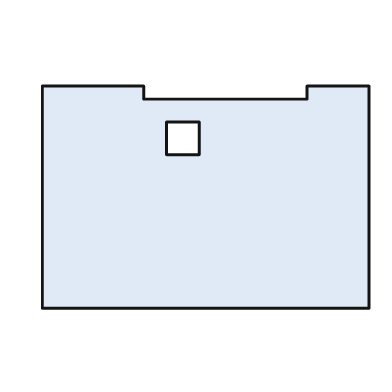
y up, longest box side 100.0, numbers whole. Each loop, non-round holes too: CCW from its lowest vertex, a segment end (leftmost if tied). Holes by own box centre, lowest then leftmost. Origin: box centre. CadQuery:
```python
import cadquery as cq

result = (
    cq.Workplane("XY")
    .moveTo(-50.0, -34.0)
    .lineTo(50.0, -34.0)
    .lineTo(50.0, 34.0)
    .lineTo(31.0, 34.0)
    .lineTo(31.0, 30.0)
    .lineTo(-19.0, 30.0)
    .lineTo(-19.0, 34.0)
    .lineTo(-50.0, 34.0)
    .close()
    .moveTo(-12.0, 13.0)
    .lineTo(-2.0, 13.0)
    .lineTo(-2.0, 23.0)
    .lineTo(-12.0, 23.0)
    .close()
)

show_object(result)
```